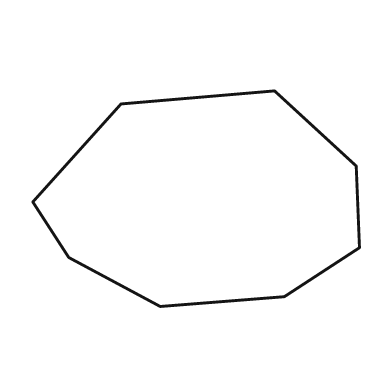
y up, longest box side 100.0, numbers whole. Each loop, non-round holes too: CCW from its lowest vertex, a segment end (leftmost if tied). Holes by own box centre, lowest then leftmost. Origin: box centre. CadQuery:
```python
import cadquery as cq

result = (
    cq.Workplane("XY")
    .moveTo(-11.0, -33.0)
    .lineTo(27.0, -30.0)
    .lineTo(50.0, -15.0)
    .lineTo(49.0, 10.0)
    .lineTo(24.0, 33.0)
    .lineTo(-23.0, 29.0)
    .lineTo(-50.0, -1.0)
    .lineTo(-39.0, -18.0)
    .close()
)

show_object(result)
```